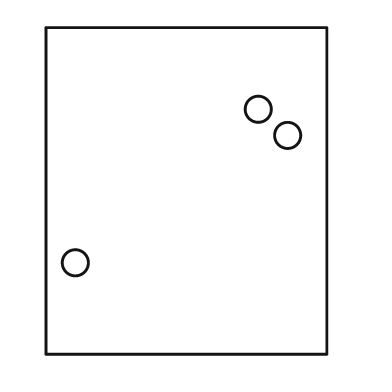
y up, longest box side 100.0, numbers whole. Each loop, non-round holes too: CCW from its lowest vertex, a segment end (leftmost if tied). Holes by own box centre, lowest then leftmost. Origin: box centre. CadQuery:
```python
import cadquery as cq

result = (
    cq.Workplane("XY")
    .moveTo(-43.0, -50.0)
    .lineTo(43.0, -50.0)
    .lineTo(43.0, 50.0)
    .lineTo(-43.0, 50.0)
    .close()
    .moveTo(-34.0, -22.0)
    .circle(4.0)
    .moveTo(31.0, 17.0)
    .circle(4.0)
    .moveTo(22.0, 25.0)
    .circle(4.0)
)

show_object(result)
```